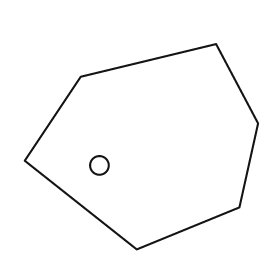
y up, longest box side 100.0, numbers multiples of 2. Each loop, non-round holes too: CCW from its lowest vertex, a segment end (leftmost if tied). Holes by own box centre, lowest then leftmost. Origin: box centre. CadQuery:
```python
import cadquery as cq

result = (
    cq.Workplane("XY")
    .moveTo(-2.0, -44.0)
    .lineTo(42.0, -26.0)
    .lineTo(50.0, 10.0)
    .lineTo(32.0, 44.0)
    .lineTo(-26.0, 30.0)
    .lineTo(-50.0, -6.0)
    .close()
    .moveTo(-18.0, -8.0)
    .circle(4.0)
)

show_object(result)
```